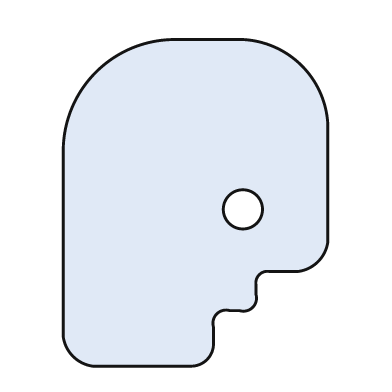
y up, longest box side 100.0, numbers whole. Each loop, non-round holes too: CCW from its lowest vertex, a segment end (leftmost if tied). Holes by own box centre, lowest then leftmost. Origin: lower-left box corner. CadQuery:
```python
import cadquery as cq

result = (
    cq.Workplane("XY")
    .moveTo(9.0, 0.0)
    .lineTo(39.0, 0.0)
    .threePointArc((44.0, 2.0), (46.0, 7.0))
    .lineTo(46.0, 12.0)
    .threePointArc((47.0, 16.0), (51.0, 17.0))
    .lineTo(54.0, 17.0)
    .threePointArc((58.0, 18.0), (59.0, 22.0))
    .lineTo(59.0, 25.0)
    .threePointArc((60.0, 28.0), (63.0, 29.0))
    .lineTo(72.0, 29.0)
    .threePointArc((78.0, 32.0), (81.0, 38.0))
    .lineTo(81.0, 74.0)
    .threePointArc((73.0, 92.0), (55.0, 100.0))
    .lineTo(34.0, 100.0)
    .threePointArc((10.0, 90.0), (0.0, 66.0))
    .lineTo(0.0, 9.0)
    .threePointArc((3.0, 3.0), (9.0, 0.0))
    .close()
    .moveTo(55.0, 48.0)
    .circle(6.0)
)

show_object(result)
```